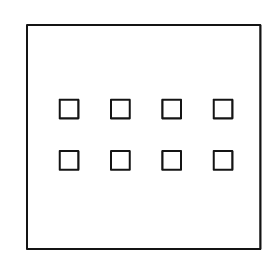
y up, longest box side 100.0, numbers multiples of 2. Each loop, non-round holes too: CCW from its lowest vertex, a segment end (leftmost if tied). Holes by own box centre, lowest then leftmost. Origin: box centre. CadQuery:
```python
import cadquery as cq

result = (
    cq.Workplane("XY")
    .moveTo(-50.0, -48.0)
    .lineTo(50.0, -48.0)
    .lineTo(50.0, 48.0)
    .lineTo(-50.0, 48.0)
    .close()
    .moveTo(-36.0, -14.0)
    .lineTo(-28.0, -14.0)
    .lineTo(-28.0, -6.0)
    .lineTo(-36.0, -6.0)
    .close()
    .moveTo(-14.0, -14.0)
    .lineTo(-6.0, -14.0)
    .lineTo(-6.0, -6.0)
    .lineTo(-14.0, -6.0)
    .close()
    .moveTo(8.0, -14.0)
    .lineTo(16.0, -14.0)
    .lineTo(16.0, -6.0)
    .lineTo(8.0, -6.0)
    .close()
    .moveTo(30.0, -14.0)
    .lineTo(38.0, -14.0)
    .lineTo(38.0, -6.0)
    .lineTo(30.0, -6.0)
    .close()
    .moveTo(-36.0, 8.0)
    .lineTo(-28.0, 8.0)
    .lineTo(-28.0, 16.0)
    .lineTo(-36.0, 16.0)
    .close()
    .moveTo(-14.0, 8.0)
    .lineTo(-6.0, 8.0)
    .lineTo(-6.0, 16.0)
    .lineTo(-14.0, 16.0)
    .close()
    .moveTo(8.0, 8.0)
    .lineTo(16.0, 8.0)
    .lineTo(16.0, 16.0)
    .lineTo(8.0, 16.0)
    .close()
    .moveTo(30.0, 8.0)
    .lineTo(38.0, 8.0)
    .lineTo(38.0, 16.0)
    .lineTo(30.0, 16.0)
    .close()
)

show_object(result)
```